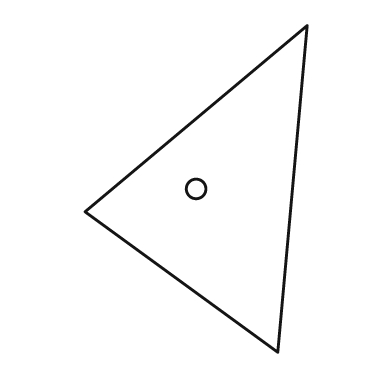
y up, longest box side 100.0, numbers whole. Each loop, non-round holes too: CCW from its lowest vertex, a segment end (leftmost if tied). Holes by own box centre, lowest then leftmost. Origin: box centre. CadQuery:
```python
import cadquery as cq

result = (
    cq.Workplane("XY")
    .moveTo(25.0, -50.0)
    .lineTo(34.0, 50.0)
    .lineTo(-34.0, -7.0)
    .close()
    .moveTo(0.0, 0.0)
    .circle(3.0)
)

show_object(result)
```